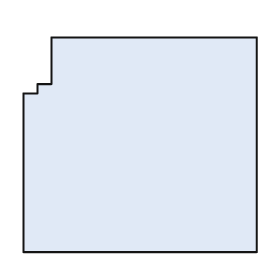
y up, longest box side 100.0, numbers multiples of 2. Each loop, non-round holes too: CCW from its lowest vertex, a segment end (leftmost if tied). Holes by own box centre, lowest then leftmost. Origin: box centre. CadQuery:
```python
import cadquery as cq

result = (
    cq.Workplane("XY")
    .moveTo(-50.0, -46.0)
    .lineTo(50.0, -46.0)
    .lineTo(50.0, 46.0)
    .lineTo(-38.0, 46.0)
    .lineTo(-38.0, 26.0)
    .lineTo(-44.0, 26.0)
    .lineTo(-44.0, 22.0)
    .lineTo(-50.0, 22.0)
    .close()
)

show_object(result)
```